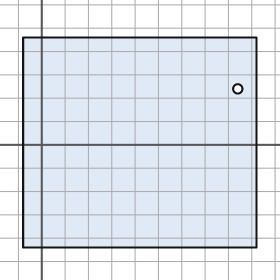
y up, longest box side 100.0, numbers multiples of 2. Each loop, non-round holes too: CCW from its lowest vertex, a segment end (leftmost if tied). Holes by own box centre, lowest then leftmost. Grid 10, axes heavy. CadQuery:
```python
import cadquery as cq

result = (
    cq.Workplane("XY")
    .moveTo(-8.0, -44.0)
    .lineTo(92.0, -44.0)
    .lineTo(92.0, 46.0)
    .lineTo(-8.0, 46.0)
    .close()
    .moveTo(84.0, 24.0)
    .circle(2.0)
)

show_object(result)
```